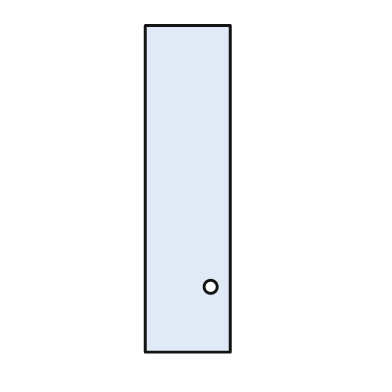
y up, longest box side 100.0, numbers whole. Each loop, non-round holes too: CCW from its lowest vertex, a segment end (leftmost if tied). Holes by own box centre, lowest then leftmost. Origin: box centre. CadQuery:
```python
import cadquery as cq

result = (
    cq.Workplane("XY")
    .moveTo(-13.0, -50.0)
    .lineTo(13.0, -50.0)
    .lineTo(13.0, 50.0)
    .lineTo(-13.0, 50.0)
    .close()
    .moveTo(7.0, -30.0)
    .circle(2.0)
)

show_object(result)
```